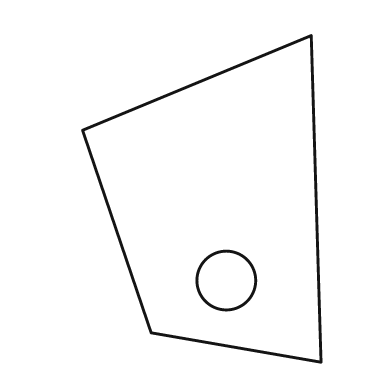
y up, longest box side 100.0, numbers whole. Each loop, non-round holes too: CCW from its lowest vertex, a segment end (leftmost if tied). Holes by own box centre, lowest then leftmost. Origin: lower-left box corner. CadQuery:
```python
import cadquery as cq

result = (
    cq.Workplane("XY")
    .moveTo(73.0, 0.0)
    .lineTo(70.0, 100.0)
    .lineTo(0.0, 71.0)
    .lineTo(21.0, 9.0)
    .close()
    .moveTo(44.0, 25.0)
    .circle(9.0)
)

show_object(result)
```